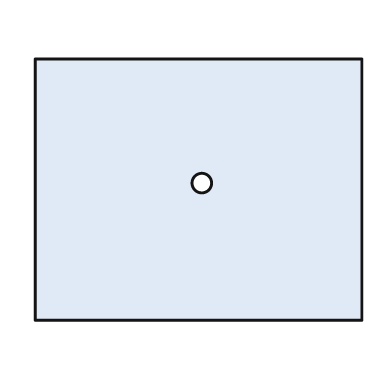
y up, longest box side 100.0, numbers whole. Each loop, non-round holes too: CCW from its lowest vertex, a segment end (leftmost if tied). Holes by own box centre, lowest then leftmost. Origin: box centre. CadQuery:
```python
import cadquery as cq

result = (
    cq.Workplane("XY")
    .moveTo(-50.0, -40.0)
    .lineTo(50.0, -40.0)
    .lineTo(50.0, 40.0)
    .lineTo(-50.0, 40.0)
    .close()
    .moveTo(1.0, 2.0)
    .circle(3.0)
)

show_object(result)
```